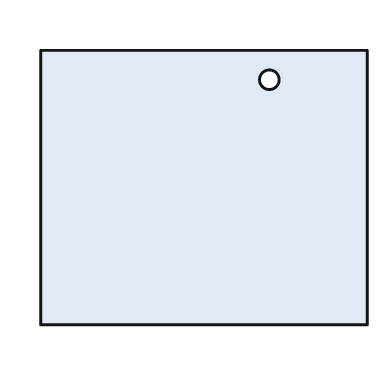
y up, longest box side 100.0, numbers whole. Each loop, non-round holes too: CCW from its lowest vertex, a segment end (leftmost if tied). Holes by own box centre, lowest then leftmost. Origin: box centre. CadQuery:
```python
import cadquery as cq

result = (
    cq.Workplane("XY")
    .moveTo(-50.0, -42.0)
    .lineTo(50.0, -42.0)
    .lineTo(50.0, 42.0)
    .lineTo(-50.0, 42.0)
    .close()
    .moveTo(20.0, 33.0)
    .circle(3.0)
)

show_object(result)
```